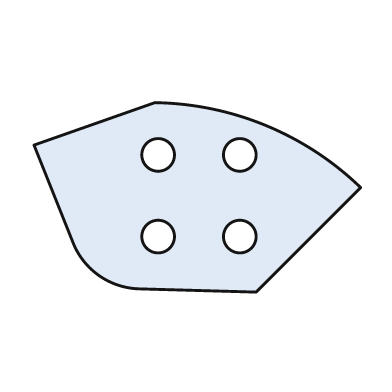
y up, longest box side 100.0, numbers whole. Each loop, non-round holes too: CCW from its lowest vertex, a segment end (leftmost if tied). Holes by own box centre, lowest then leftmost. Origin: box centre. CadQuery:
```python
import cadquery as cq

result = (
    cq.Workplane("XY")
    .moveTo(18.0, -29.0)
    .lineTo(50.0, 3.0)
    .threePointArc((21.0, 22.0), (-13.0, 29.0))
    .lineTo(-50.0, 16.0)
    .lineTo(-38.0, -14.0)
    .threePointArc((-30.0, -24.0), (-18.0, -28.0))
    .close()
    .moveTo(-12.0, -12.0)
    .circle(5.0)
    .moveTo(13.0, -12.0)
    .circle(5.0)
    .moveTo(-12.0, 13.0)
    .circle(5.0)
    .moveTo(13.0, 13.0)
    .circle(5.0)
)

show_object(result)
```